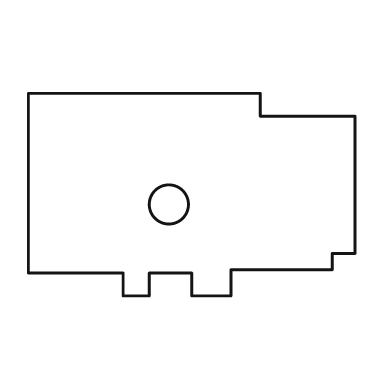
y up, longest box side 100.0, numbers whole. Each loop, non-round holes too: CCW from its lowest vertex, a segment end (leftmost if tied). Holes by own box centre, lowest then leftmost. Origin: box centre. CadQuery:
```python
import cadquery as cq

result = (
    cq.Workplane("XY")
    .moveTo(-21.0, -31.0)
    .lineTo(-13.0, -31.0)
    .lineTo(-13.0, -24.0)
    .lineTo(0.0, -24.0)
    .lineTo(0.0, -31.0)
    .lineTo(12.0, -31.0)
    .lineTo(12.0, -23.0)
    .lineTo(43.0, -23.0)
    .lineTo(43.0, -18.0)
    .lineTo(50.0, -18.0)
    .lineTo(50.0, 24.0)
    .lineTo(21.0, 24.0)
    .lineTo(21.0, 31.0)
    .lineTo(-50.0, 31.0)
    .lineTo(-50.0, -24.0)
    .lineTo(-21.0, -24.0)
    .close()
    .moveTo(-7.0, -3.0)
    .circle(6.0)
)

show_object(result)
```